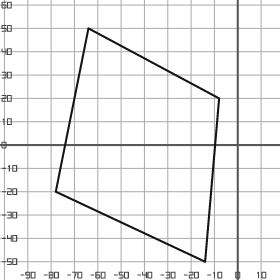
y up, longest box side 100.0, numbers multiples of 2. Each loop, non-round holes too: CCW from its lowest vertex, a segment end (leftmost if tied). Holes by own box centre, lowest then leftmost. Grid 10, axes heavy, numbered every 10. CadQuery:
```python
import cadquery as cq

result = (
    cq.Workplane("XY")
    .moveTo(-14.0, -50.0)
    .lineTo(-8.0, 20.0)
    .lineTo(-64.0, 50.0)
    .lineTo(-78.0, -20.0)
    .close()
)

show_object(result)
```